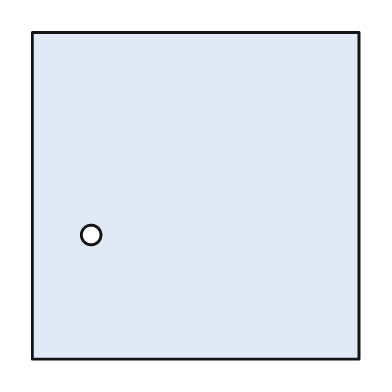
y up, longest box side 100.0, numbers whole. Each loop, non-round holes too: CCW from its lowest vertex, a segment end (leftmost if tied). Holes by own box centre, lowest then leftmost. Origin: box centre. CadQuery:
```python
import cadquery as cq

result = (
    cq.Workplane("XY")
    .moveTo(-50.0, -50.0)
    .lineTo(50.0, -50.0)
    .lineTo(50.0, 50.0)
    .lineTo(-50.0, 50.0)
    .close()
    .moveTo(-32.0, -12.0)
    .circle(3.0)
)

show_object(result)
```